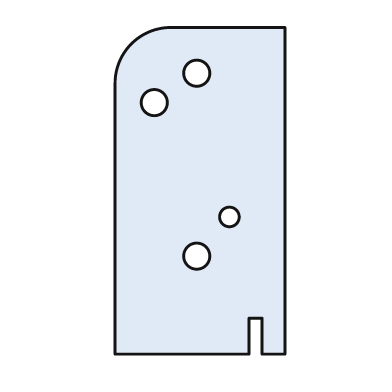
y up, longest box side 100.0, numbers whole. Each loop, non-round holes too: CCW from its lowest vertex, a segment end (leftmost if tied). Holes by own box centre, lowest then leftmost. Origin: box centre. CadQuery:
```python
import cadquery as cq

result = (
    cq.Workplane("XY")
    .moveTo(-26.0, -50.0)
    .lineTo(15.0, -50.0)
    .lineTo(15.0, -39.0)
    .lineTo(19.0, -39.0)
    .lineTo(19.0, -50.0)
    .lineTo(26.0, -50.0)
    .lineTo(26.0, 50.0)
    .lineTo(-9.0, 50.0)
    .threePointArc((-21.0, 45.0), (-26.0, 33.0))
    .close()
    .moveTo(-1.0, -20.0)
    .circle(4.0)
    .moveTo(9.0, -8.0)
    .circle(3.0)
    .moveTo(-14.0, 27.0)
    .circle(4.0)
    .moveTo(-1.0, 36.0)
    .circle(4.0)
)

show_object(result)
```